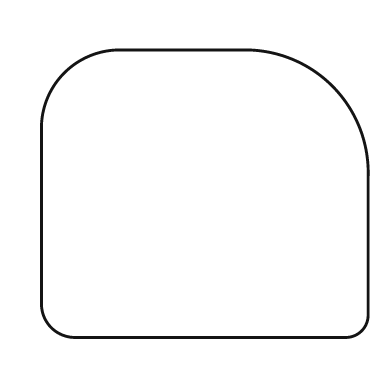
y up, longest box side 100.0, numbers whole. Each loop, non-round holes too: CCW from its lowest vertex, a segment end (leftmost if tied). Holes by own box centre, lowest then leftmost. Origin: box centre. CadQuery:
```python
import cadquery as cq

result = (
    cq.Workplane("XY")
    .moveTo(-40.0, -44.0)
    .lineTo(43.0, -44.0)
    .threePointArc((48.0, -42.0), (50.0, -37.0))
    .lineTo(50.0, 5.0)
    .threePointArc((39.0, 33.0), (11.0, 44.0))
    .lineTo(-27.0, 44.0)
    .threePointArc((-43.0, 37.0), (-50.0, 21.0))
    .lineTo(-50.0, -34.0)
    .threePointArc((-47.0, -41.0), (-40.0, -44.0))
    .close()
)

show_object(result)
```